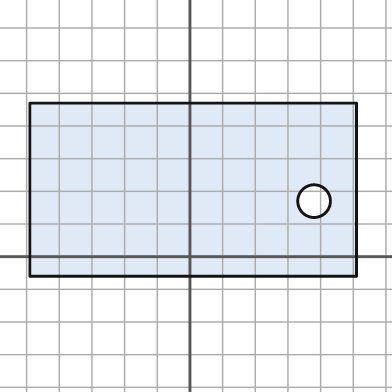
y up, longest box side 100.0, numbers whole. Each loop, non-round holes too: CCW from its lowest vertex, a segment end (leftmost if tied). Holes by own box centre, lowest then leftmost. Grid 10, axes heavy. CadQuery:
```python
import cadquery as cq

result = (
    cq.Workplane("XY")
    .moveTo(-49.0, -6.0)
    .lineTo(51.0, -6.0)
    .lineTo(51.0, 47.0)
    .lineTo(-49.0, 47.0)
    .close()
    .moveTo(38.0, 17.0)
    .circle(5.0)
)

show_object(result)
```